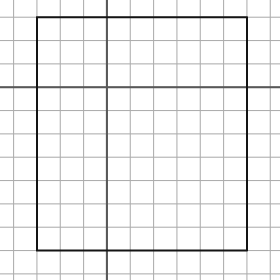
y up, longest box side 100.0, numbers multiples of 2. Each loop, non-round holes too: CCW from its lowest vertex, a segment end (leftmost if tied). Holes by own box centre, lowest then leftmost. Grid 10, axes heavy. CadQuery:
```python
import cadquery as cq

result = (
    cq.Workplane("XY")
    .moveTo(-30.0, -70.0)
    .lineTo(60.0, -70.0)
    .lineTo(60.0, 30.0)
    .lineTo(-30.0, 30.0)
    .close()
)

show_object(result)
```